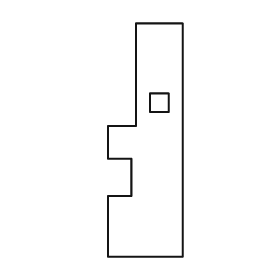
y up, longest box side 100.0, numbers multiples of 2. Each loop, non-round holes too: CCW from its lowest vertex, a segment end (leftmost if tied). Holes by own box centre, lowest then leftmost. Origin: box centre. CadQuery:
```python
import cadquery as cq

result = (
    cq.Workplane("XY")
    .moveTo(-16.0, -50.0)
    .lineTo(16.0, -50.0)
    .lineTo(16.0, 50.0)
    .lineTo(-4.0, 50.0)
    .lineTo(-4.0, 6.0)
    .lineTo(-16.0, 6.0)
    .lineTo(-16.0, -8.0)
    .lineTo(-6.0, -8.0)
    .lineTo(-6.0, -24.0)
    .lineTo(-16.0, -24.0)
    .close()
    .moveTo(2.0, 12.0)
    .lineTo(10.0, 12.0)
    .lineTo(10.0, 20.0)
    .lineTo(2.0, 20.0)
    .close()
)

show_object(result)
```